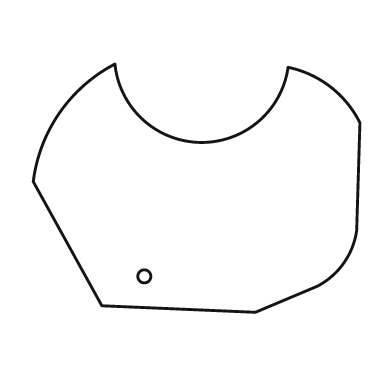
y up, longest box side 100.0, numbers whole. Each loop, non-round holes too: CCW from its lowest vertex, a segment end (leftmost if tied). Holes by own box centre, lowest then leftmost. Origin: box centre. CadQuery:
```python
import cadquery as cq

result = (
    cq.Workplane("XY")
    .moveTo(18.0, -38.0)
    .lineTo(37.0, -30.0)
    .threePointArc((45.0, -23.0), (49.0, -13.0))
    .lineTo(50.0, 20.0)
    .threePointArc((41.0, 31.0), (28.0, 37.0))
    .threePointArc((1.0, 14.0), (-25.0, 38.0))
    .threePointArc((-42.0, 23.0), (-50.0, 2.0))
    .lineTo(-29.0, -36.0)
    .close()
    .moveTo(-16.0, -27.0)
    .circle(2.0)
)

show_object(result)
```